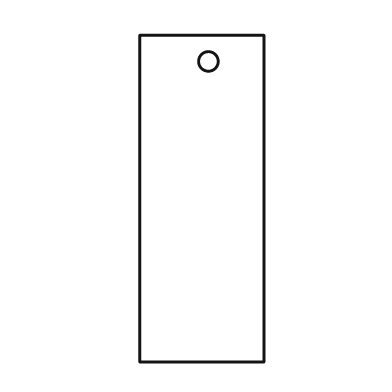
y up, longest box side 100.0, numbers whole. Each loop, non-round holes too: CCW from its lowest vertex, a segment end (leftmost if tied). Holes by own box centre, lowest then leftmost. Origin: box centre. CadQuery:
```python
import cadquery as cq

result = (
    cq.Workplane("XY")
    .moveTo(-19.0, -50.0)
    .lineTo(19.0, -50.0)
    .lineTo(19.0, 50.0)
    .lineTo(-19.0, 50.0)
    .close()
    .moveTo(2.0, 42.0)
    .circle(3.0)
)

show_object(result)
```